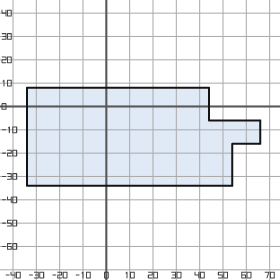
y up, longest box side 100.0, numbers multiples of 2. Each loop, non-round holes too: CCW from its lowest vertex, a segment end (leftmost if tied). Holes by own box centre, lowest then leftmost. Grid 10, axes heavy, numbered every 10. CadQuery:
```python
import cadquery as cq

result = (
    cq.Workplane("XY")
    .moveTo(-34.0, -34.0)
    .lineTo(54.0, -34.0)
    .lineTo(54.0, -16.0)
    .lineTo(66.0, -16.0)
    .lineTo(66.0, -6.0)
    .lineTo(44.0, -6.0)
    .lineTo(44.0, 8.0)
    .lineTo(-34.0, 8.0)
    .close()
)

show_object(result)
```